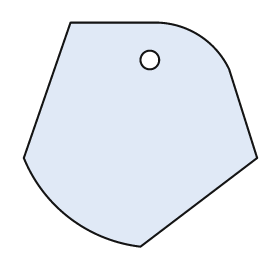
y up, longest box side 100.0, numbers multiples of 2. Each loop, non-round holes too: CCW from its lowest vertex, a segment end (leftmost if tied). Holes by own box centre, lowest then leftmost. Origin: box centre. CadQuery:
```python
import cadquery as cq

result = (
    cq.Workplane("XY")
    .moveTo(0.0, -48.0)
    .lineTo(50.0, -10.0)
    .lineTo(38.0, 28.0)
    .threePointArc((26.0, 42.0), (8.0, 48.0))
    .lineTo(-30.0, 48.0)
    .lineTo(-50.0, -10.0)
    .threePointArc((-30.0, -36.0), (0.0, -48.0))
    .close()
    .moveTo(4.0, 32.0)
    .circle(4.0)
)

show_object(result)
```